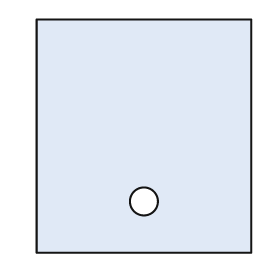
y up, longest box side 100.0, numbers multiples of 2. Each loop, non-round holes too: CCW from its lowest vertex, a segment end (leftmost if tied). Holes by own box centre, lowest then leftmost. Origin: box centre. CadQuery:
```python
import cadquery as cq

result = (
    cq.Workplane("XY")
    .moveTo(-46.0, -50.0)
    .lineTo(46.0, -50.0)
    .lineTo(46.0, 50.0)
    .lineTo(-46.0, 50.0)
    .close()
    .moveTo(0.0, -28.0)
    .circle(6.0)
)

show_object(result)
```